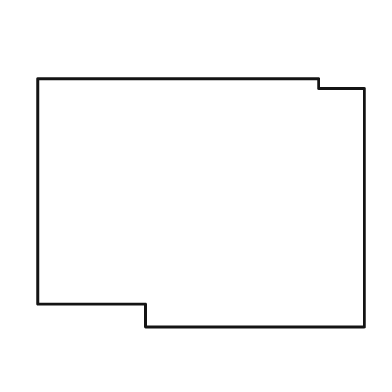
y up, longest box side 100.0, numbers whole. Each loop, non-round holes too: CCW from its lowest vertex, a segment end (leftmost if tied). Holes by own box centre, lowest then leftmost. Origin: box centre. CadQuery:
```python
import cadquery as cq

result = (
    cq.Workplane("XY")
    .moveTo(-17.0, -38.0)
    .lineTo(50.0, -38.0)
    .lineTo(50.0, 35.0)
    .lineTo(36.0, 35.0)
    .lineTo(36.0, 38.0)
    .lineTo(-50.0, 38.0)
    .lineTo(-50.0, -31.0)
    .lineTo(-17.0, -31.0)
    .close()
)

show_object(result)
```